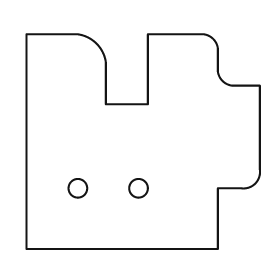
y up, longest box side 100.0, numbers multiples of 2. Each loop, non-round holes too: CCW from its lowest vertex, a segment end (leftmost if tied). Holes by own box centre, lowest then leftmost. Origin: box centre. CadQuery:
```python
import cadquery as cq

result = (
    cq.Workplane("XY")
    .moveTo(-50.0, -46.0)
    .lineTo(32.0, -46.0)
    .lineTo(32.0, -20.0)
    .lineTo(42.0, -20.0)
    .threePointArc((48.0, -18.0), (50.0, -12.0))
    .lineTo(50.0, 24.0)
    .lineTo(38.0, 24.0)
    .threePointArc((34.0, 26.0), (32.0, 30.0))
    .lineTo(32.0, 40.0)
    .threePointArc((30.0, 44.0), (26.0, 46.0))
    .lineTo(2.0, 46.0)
    .lineTo(2.0, 16.0)
    .lineTo(-16.0, 16.0)
    .lineTo(-16.0, 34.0)
    .threePointArc((-20.0, 42.0), (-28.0, 46.0))
    .lineTo(-50.0, 46.0)
    .close()
    .moveTo(-28.0, -20.0)
    .circle(4.0)
    .moveTo(-2.0, -20.0)
    .circle(4.0)
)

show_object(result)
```